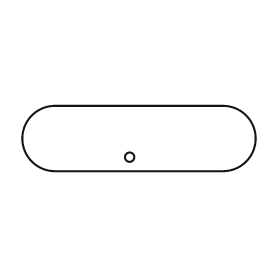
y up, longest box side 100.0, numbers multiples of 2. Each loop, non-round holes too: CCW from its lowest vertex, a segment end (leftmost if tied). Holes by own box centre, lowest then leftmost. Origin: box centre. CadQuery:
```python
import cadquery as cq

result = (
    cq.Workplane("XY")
    .moveTo(-36.0, -14.0)
    .lineTo(36.0, -14.0)
    .threePointArc((50.0, 0.0), (36.0, 14.0))
    .lineTo(-36.0, 14.0)
    .threePointArc((-50.0, 0.0), (-36.0, -14.0))
    .close()
    .moveTo(-4.0, -8.0)
    .circle(2.0)
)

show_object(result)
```